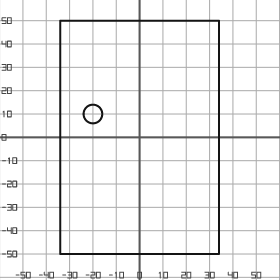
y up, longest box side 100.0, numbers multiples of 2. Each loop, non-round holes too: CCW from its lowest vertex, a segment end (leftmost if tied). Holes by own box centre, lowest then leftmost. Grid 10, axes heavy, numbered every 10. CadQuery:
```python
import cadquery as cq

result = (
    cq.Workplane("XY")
    .moveTo(-34.0, -50.0)
    .lineTo(34.0, -50.0)
    .lineTo(34.0, 50.0)
    .lineTo(-34.0, 50.0)
    .close()
    .moveTo(-20.0, 10.0)
    .circle(4.0)
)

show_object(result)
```